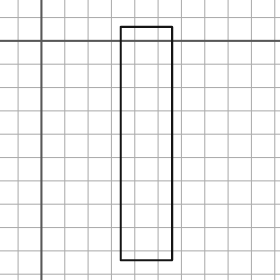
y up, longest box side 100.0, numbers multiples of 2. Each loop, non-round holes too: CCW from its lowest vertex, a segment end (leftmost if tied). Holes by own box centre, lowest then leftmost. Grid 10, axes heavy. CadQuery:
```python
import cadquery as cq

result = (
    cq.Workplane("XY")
    .moveTo(34.0, -94.0)
    .lineTo(56.0, -94.0)
    .lineTo(56.0, 6.0)
    .lineTo(34.0, 6.0)
    .close()
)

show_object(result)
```